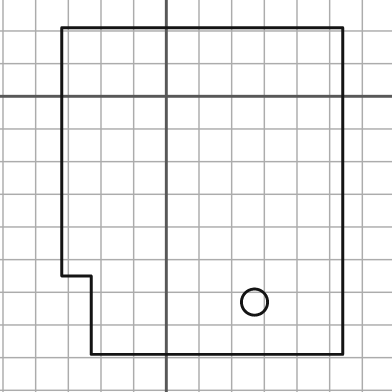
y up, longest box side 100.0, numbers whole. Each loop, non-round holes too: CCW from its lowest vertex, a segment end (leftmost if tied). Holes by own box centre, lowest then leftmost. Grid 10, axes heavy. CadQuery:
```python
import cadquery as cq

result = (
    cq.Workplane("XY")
    .moveTo(-23.0, -79.0)
    .lineTo(54.0, -79.0)
    .lineTo(54.0, 21.0)
    .lineTo(-32.0, 21.0)
    .lineTo(-32.0, -55.0)
    .lineTo(-23.0, -55.0)
    .close()
    .moveTo(27.0, -63.0)
    .circle(4.0)
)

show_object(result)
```